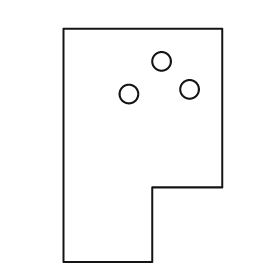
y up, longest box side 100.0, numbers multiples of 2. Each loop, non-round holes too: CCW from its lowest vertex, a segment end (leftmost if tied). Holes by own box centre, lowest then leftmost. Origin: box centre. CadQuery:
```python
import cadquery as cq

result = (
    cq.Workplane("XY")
    .moveTo(-34.0, -50.0)
    .lineTo(4.0, -50.0)
    .lineTo(4.0, -18.0)
    .lineTo(34.0, -18.0)
    .lineTo(34.0, 50.0)
    .lineTo(-34.0, 50.0)
    .close()
    .moveTo(-6.0, 22.0)
    .circle(4.0)
    .moveTo(20.0, 24.0)
    .circle(4.0)
    .moveTo(8.0, 36.0)
    .circle(4.0)
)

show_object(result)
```